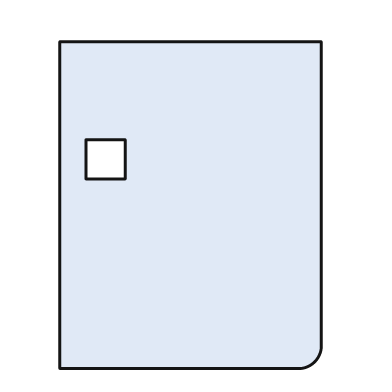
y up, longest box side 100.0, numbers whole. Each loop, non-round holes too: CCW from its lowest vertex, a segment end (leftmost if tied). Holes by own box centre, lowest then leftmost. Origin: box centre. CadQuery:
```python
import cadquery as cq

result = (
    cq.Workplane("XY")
    .moveTo(-40.0, -50.0)
    .lineTo(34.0, -50.0)
    .threePointArc((38.0, -48.0), (40.0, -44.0))
    .lineTo(40.0, 50.0)
    .lineTo(-40.0, 50.0)
    .close()
    .moveTo(-32.0, 8.0)
    .lineTo(-20.0, 8.0)
    .lineTo(-20.0, 20.0)
    .lineTo(-32.0, 20.0)
    .close()
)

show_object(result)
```